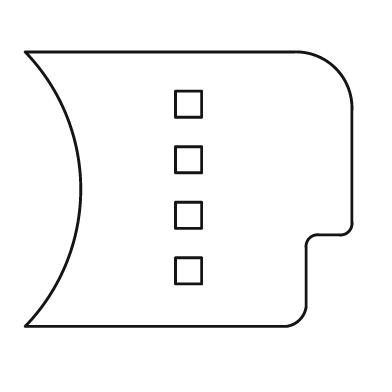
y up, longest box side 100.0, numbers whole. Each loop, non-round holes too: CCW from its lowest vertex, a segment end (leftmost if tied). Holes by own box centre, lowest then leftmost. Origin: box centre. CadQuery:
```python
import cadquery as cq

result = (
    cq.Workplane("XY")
    .moveTo(-50.0, -42.0)
    .lineTo(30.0, -42.0)
    .threePointArc((34.0, -40.0), (36.0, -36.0))
    .lineTo(36.0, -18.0)
    .threePointArc((37.0, -15.0), (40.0, -14.0))
    .lineTo(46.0, -14.0)
    .threePointArc((49.0, -13.0), (50.0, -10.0))
    .lineTo(50.0, 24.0)
    .threePointArc((45.0, 37.0), (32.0, 42.0))
    .lineTo(-50.0, 42.0)
    .threePointArc((-33.0, 0.0), (-50.0, -42.0))
    .close()
    .moveTo(-4.0, -29.0)
    .lineTo(4.0, -29.0)
    .lineTo(4.0, -21.0)
    .lineTo(-4.0, -21.0)
    .close()
    .moveTo(-4.0, -12.0)
    .lineTo(4.0, -12.0)
    .lineTo(4.0, -4.0)
    .lineTo(-4.0, -4.0)
    .close()
    .moveTo(-4.0, 5.0)
    .lineTo(4.0, 5.0)
    .lineTo(4.0, 13.0)
    .lineTo(-4.0, 13.0)
    .close()
    .moveTo(-4.0, 22.0)
    .lineTo(4.0, 22.0)
    .lineTo(4.0, 30.0)
    .lineTo(-4.0, 30.0)
    .close()
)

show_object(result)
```